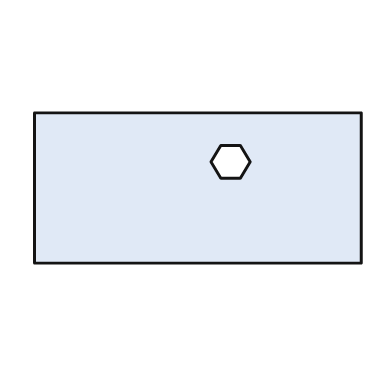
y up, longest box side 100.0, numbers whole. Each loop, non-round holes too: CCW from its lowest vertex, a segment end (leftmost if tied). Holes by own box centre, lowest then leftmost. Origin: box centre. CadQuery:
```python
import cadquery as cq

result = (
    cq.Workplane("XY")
    .moveTo(-50.0, -23.0)
    .lineTo(50.0, -23.0)
    .lineTo(50.0, 23.0)
    .lineTo(-50.0, 23.0)
    .close()
    .moveTo(7.0, 3.0)
    .lineTo(13.0, 3.0)
    .lineTo(16.0, 8.0)
    .lineTo(13.0, 13.0)
    .lineTo(7.0, 13.0)
    .lineTo(4.0, 8.0)
    .close()
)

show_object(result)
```